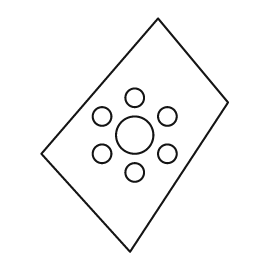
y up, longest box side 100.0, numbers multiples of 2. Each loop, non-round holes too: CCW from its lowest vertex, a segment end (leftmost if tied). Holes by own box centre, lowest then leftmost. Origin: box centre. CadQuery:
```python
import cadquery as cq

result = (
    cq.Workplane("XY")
    .moveTo(-2.0, -50.0)
    .lineTo(40.0, 14.0)
    .lineTo(10.0, 50.0)
    .lineTo(-40.0, -8.0)
    .close()
    .moveTo(0.0, -16.0)
    .circle(4.0)
    .moveTo(-14.0, -8.0)
    .circle(4.0)
    .moveTo(14.0, -8.0)
    .circle(4.0)
    .moveTo(0.0, 0.0)
    .circle(8.0)
    .moveTo(-14.0, 8.0)
    .circle(4.0)
    .moveTo(14.0, 8.0)
    .circle(4.0)
    .moveTo(0.0, 16.0)
    .circle(4.0)
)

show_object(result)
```